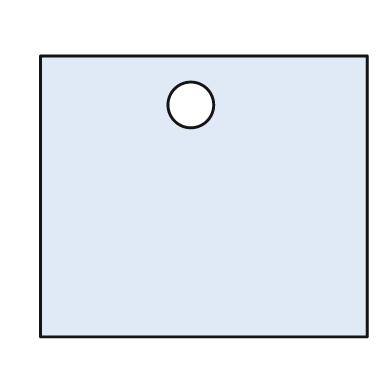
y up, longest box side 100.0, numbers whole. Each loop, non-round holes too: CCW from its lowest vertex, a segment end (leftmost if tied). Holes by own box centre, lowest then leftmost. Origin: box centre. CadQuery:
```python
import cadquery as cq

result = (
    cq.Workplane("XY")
    .moveTo(-50.0, -43.0)
    .lineTo(50.0, -43.0)
    .lineTo(50.0, 43.0)
    .lineTo(-50.0, 43.0)
    .close()
    .moveTo(-4.0, 28.0)
    .circle(7.0)
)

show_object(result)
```